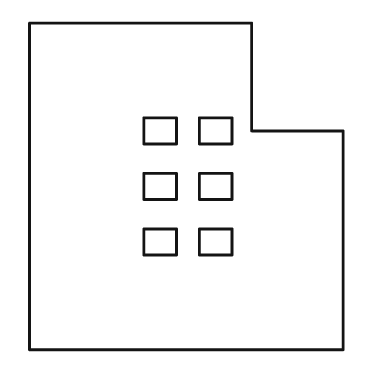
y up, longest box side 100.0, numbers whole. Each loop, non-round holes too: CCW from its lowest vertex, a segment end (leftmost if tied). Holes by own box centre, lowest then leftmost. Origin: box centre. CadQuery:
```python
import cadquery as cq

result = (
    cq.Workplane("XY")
    .moveTo(-48.0, -50.0)
    .lineTo(48.0, -50.0)
    .lineTo(48.0, 17.0)
    .lineTo(20.0, 17.0)
    .lineTo(20.0, 50.0)
    .lineTo(-48.0, 50.0)
    .close()
    .moveTo(-13.0, -21.0)
    .lineTo(-3.0, -21.0)
    .lineTo(-3.0, -13.0)
    .lineTo(-13.0, -13.0)
    .close()
    .moveTo(4.0, -21.0)
    .lineTo(14.0, -21.0)
    .lineTo(14.0, -13.0)
    .lineTo(4.0, -13.0)
    .close()
    .moveTo(-13.0, -4.0)
    .lineTo(-3.0, -4.0)
    .lineTo(-3.0, 4.0)
    .lineTo(-13.0, 4.0)
    .close()
    .moveTo(4.0, -4.0)
    .lineTo(14.0, -4.0)
    .lineTo(14.0, 4.0)
    .lineTo(4.0, 4.0)
    .close()
    .moveTo(-13.0, 13.0)
    .lineTo(-3.0, 13.0)
    .lineTo(-3.0, 21.0)
    .lineTo(-13.0, 21.0)
    .close()
    .moveTo(4.0, 13.0)
    .lineTo(14.0, 13.0)
    .lineTo(14.0, 21.0)
    .lineTo(4.0, 21.0)
    .close()
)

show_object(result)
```